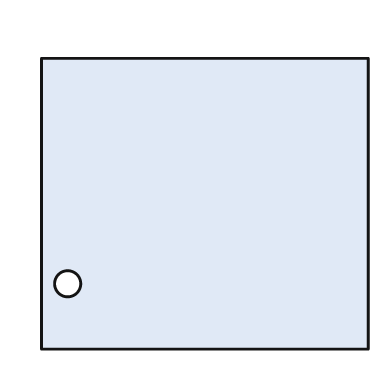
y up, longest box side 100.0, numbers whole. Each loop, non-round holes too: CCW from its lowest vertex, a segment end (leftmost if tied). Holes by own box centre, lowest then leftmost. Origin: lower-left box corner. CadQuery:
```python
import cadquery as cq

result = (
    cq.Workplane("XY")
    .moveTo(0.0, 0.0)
    .lineTo(100.0, 0.0)
    .lineTo(100.0, 89.0)
    .lineTo(0.0, 89.0)
    .close()
    .moveTo(8.0, 20.0)
    .circle(4.0)
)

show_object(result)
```